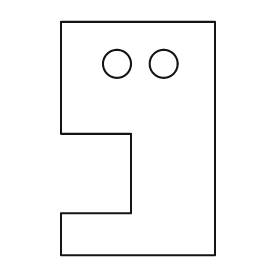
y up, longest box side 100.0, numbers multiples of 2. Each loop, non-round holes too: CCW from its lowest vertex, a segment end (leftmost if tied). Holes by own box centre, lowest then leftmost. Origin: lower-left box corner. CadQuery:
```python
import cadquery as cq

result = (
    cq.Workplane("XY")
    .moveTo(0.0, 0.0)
    .lineTo(66.0, 0.0)
    .lineTo(66.0, 100.0)
    .lineTo(0.0, 100.0)
    .lineTo(0.0, 52.0)
    .lineTo(30.0, 52.0)
    .lineTo(30.0, 18.0)
    .lineTo(0.0, 18.0)
    .close()
    .moveTo(24.0, 82.0)
    .circle(6.0)
    .moveTo(44.0, 82.0)
    .circle(6.0)
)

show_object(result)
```